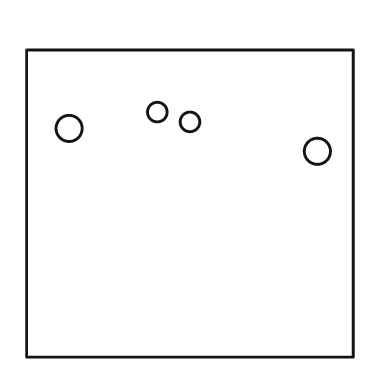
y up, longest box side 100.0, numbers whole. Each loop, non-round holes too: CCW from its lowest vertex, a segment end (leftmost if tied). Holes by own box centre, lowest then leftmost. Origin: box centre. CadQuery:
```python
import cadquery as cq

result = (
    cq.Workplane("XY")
    .moveTo(-50.0, -47.0)
    .lineTo(50.0, -47.0)
    .lineTo(50.0, 47.0)
    .lineTo(-50.0, 47.0)
    .close()
    .moveTo(39.0, 16.0)
    .circle(4.0)
    .moveTo(-37.0, 23.0)
    .circle(4.0)
    .moveTo(0.0, 25.0)
    .circle(3.0)
    .moveTo(-10.0, 28.0)
    .circle(3.0)
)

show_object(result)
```